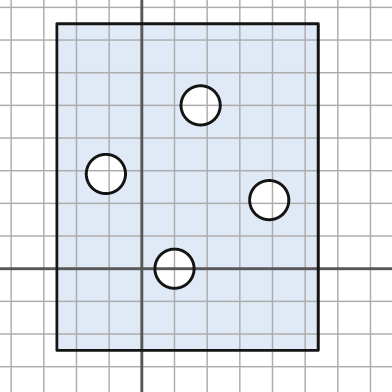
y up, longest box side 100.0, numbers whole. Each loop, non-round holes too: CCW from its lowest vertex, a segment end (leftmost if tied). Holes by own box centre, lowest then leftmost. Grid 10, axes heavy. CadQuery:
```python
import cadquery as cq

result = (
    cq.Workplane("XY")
    .moveTo(-26.0, -25.0)
    .lineTo(54.0, -25.0)
    .lineTo(54.0, 75.0)
    .lineTo(-26.0, 75.0)
    .close()
    .moveTo(10.0, 0.0)
    .circle(6.0)
    .moveTo(39.0, 21.0)
    .circle(6.0)
    .moveTo(-11.0, 29.0)
    .circle(6.0)
    .moveTo(18.0, 50.0)
    .circle(6.0)
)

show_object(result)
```